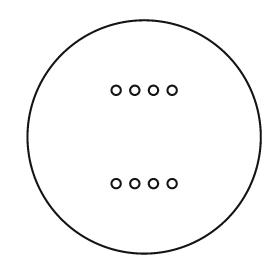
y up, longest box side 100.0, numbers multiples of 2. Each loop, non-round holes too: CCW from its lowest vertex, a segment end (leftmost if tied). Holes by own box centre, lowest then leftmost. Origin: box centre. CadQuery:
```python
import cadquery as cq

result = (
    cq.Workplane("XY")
    .moveTo(0.0, 0.0)
    .circle(50.0)
    .moveTo(-12.0, -20.0)
    .circle(2.0)
    .moveTo(-4.0, -20.0)
    .circle(2.0)
    .moveTo(4.0, -20.0)
    .circle(2.0)
    .moveTo(12.0, -20.0)
    .circle(2.0)
    .moveTo(-12.0, 20.0)
    .circle(2.0)
    .moveTo(-4.0, 20.0)
    .circle(2.0)
    .moveTo(4.0, 20.0)
    .circle(2.0)
    .moveTo(12.0, 20.0)
    .circle(2.0)
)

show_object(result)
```